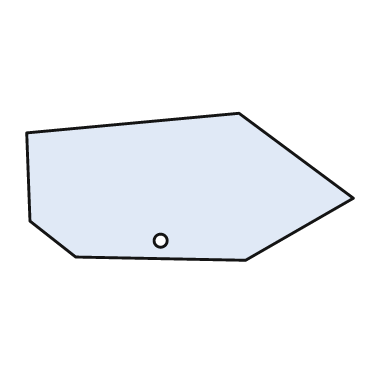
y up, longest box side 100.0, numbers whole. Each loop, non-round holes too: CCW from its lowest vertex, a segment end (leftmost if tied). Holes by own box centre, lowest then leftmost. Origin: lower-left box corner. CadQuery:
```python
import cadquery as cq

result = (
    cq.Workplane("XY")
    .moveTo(67.0, 0.0)
    .lineTo(100.0, 19.0)
    .lineTo(65.0, 45.0)
    .lineTo(0.0, 39.0)
    .lineTo(1.0, 12.0)
    .lineTo(15.0, 1.0)
    .close()
    .moveTo(41.0, 6.0)
    .circle(2.0)
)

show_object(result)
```